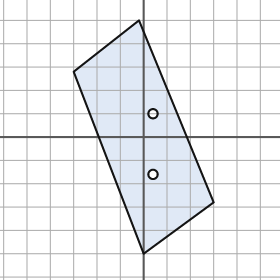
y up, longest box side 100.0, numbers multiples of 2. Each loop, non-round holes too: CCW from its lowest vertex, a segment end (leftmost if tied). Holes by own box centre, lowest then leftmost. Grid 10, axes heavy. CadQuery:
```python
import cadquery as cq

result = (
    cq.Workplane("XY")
    .moveTo(0.0, -50.0)
    .lineTo(30.0, -28.0)
    .lineTo(-2.0, 50.0)
    .lineTo(-30.0, 28.0)
    .close()
    .moveTo(4.0, -16.0)
    .circle(2.0)
    .moveTo(4.0, 10.0)
    .circle(2.0)
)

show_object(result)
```